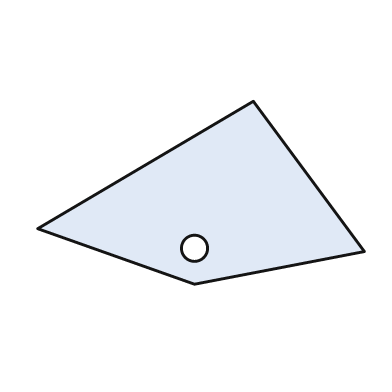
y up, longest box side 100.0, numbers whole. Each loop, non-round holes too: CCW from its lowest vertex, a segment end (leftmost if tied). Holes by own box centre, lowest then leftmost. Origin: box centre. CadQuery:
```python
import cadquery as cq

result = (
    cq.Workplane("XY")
    .moveTo(-2.0, -28.0)
    .lineTo(50.0, -18.0)
    .lineTo(16.0, 28.0)
    .lineTo(-50.0, -11.0)
    .close()
    .moveTo(-2.0, -17.0)
    .circle(4.0)
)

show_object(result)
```